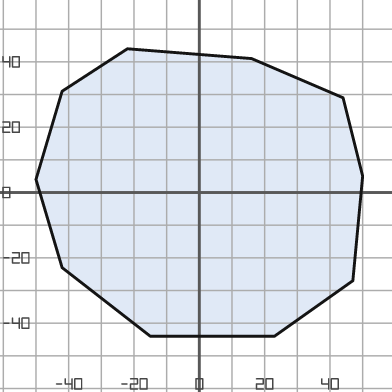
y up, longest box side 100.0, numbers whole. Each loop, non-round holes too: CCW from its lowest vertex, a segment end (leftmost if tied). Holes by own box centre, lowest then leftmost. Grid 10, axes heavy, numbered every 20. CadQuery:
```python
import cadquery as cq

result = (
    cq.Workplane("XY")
    .moveTo(-15.0, -44.0)
    .lineTo(23.0, -44.0)
    .lineTo(47.0, -27.0)
    .lineTo(50.0, 5.0)
    .lineTo(44.0, 29.0)
    .lineTo(16.0, 41.0)
    .lineTo(-22.0, 44.0)
    .lineTo(-42.0, 31.0)
    .lineTo(-50.0, 4.0)
    .lineTo(-42.0, -23.0)
    .close()
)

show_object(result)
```